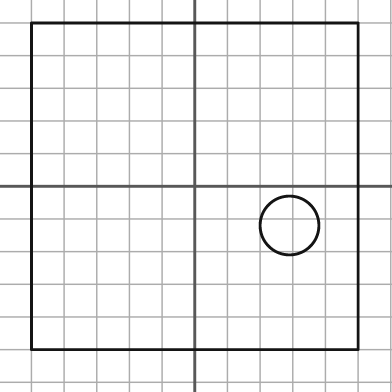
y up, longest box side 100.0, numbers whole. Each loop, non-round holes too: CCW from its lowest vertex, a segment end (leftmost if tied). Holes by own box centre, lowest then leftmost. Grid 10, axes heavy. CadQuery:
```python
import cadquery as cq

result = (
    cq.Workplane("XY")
    .moveTo(-50.0, -50.0)
    .lineTo(50.0, -50.0)
    .lineTo(50.0, 50.0)
    .lineTo(-50.0, 50.0)
    .close()
    .moveTo(29.0, -12.0)
    .circle(9.0)
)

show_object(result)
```